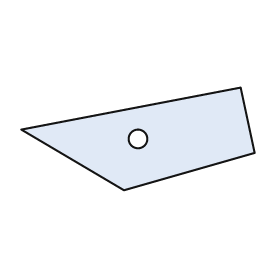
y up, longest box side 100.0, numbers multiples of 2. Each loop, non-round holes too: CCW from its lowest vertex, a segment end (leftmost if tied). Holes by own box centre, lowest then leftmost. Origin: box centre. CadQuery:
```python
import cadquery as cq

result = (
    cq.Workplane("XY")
    .moveTo(-6.0, -22.0)
    .lineTo(50.0, -6.0)
    .lineTo(44.0, 22.0)
    .lineTo(-50.0, 4.0)
    .close()
    .moveTo(0.0, 0.0)
    .circle(4.0)
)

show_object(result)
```